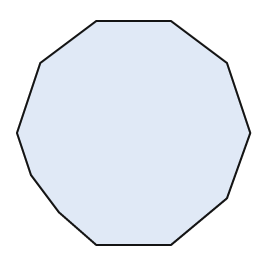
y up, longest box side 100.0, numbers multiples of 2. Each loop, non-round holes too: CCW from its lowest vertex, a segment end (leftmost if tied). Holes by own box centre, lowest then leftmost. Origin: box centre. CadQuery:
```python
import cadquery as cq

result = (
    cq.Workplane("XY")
    .moveTo(-16.0, -48.0)
    .lineTo(16.0, -48.0)
    .lineTo(40.0, -28.0)
    .lineTo(50.0, 0.0)
    .lineTo(40.0, 30.0)
    .lineTo(16.0, 48.0)
    .lineTo(-16.0, 48.0)
    .lineTo(-40.0, 30.0)
    .lineTo(-50.0, 0.0)
    .lineTo(-44.0, -18.0)
    .lineTo(-32.0, -34.0)
    .close()
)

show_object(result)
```